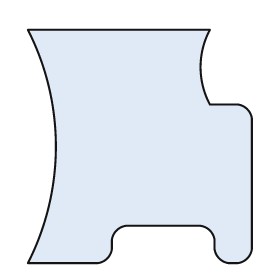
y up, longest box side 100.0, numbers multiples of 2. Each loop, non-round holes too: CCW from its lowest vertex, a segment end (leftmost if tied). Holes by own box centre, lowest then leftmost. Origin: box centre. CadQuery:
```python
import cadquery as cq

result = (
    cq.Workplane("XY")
    .moveTo(-48.0, -50.0)
    .lineTo(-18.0, -50.0)
    .threePointArc((-14.0, -48.0), (-12.0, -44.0))
    .lineTo(-12.0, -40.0)
    .threePointArc((-10.0, -36.0), (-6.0, -34.0))
    .lineTo(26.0, -34.0)
    .threePointArc((30.0, -36.0), (32.0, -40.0))
    .lineTo(32.0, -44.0)
    .threePointArc((34.0, -48.0), (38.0, -50.0))
    .lineTo(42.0, -50.0)
    .threePointArc((46.0, -48.0), (48.0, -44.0))
    .lineTo(48.0, 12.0)
    .threePointArc((46.0, 16.0), (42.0, 18.0))
    .lineTo(30.0, 18.0)
    .threePointArc((26.0, 34.0), (30.0, 50.0))
    .lineTo(-48.0, 50.0)
    .threePointArc((-36.0, 0.0), (-48.0, -50.0))
    .close()
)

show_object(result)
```